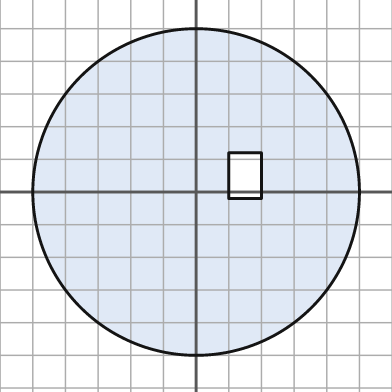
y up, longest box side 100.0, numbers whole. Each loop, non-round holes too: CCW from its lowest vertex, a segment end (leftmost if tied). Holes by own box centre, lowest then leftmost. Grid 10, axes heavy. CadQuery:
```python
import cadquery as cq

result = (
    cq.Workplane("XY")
    .moveTo(0.0, 0.0)
    .circle(50.0)
    .moveTo(10.0, -2.0)
    .lineTo(20.0, -2.0)
    .lineTo(20.0, 12.0)
    .lineTo(10.0, 12.0)
    .close()
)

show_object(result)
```